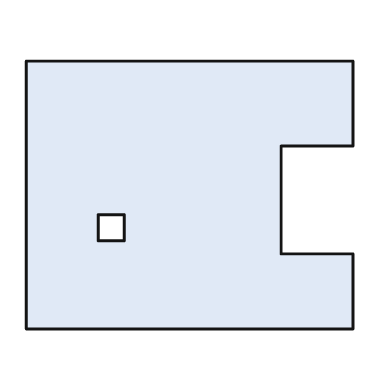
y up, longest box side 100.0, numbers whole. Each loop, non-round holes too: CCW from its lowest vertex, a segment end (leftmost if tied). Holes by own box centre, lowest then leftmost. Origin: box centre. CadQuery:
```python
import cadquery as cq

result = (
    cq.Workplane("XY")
    .moveTo(-50.0, -41.0)
    .lineTo(50.0, -41.0)
    .lineTo(50.0, -18.0)
    .lineTo(28.0, -18.0)
    .lineTo(28.0, 15.0)
    .lineTo(50.0, 15.0)
    .lineTo(50.0, 41.0)
    .lineTo(-50.0, 41.0)
    .close()
    .moveTo(-28.0, -14.0)
    .lineTo(-20.0, -14.0)
    .lineTo(-20.0, -6.0)
    .lineTo(-28.0, -6.0)
    .close()
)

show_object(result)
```